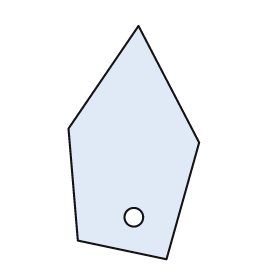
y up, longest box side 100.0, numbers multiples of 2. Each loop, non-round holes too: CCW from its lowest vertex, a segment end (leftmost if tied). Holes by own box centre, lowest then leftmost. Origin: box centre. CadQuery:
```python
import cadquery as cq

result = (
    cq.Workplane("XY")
    .moveTo(14.0, -50.0)
    .lineTo(28.0, 0.0)
    .lineTo(2.0, 50.0)
    .lineTo(-28.0, 6.0)
    .lineTo(-24.0, -42.0)
    .close()
    .moveTo(0.0, -32.0)
    .circle(4.0)
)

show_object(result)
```